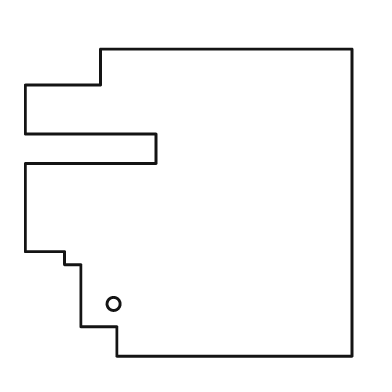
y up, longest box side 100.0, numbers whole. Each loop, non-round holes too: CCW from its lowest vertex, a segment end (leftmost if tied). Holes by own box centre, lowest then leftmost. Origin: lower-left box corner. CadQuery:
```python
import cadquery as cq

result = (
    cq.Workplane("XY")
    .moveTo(28.0, 0.0)
    .lineTo(100.0, 0.0)
    .lineTo(100.0, 94.0)
    .lineTo(23.0, 94.0)
    .lineTo(23.0, 83.0)
    .lineTo(0.0, 83.0)
    .lineTo(0.0, 68.0)
    .lineTo(40.0, 68.0)
    .lineTo(40.0, 59.0)
    .lineTo(0.0, 59.0)
    .lineTo(0.0, 32.0)
    .lineTo(12.0, 32.0)
    .lineTo(12.0, 28.0)
    .lineTo(17.0, 28.0)
    .lineTo(17.0, 9.0)
    .lineTo(28.0, 9.0)
    .close()
    .moveTo(27.0, 16.0)
    .circle(2.0)
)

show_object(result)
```